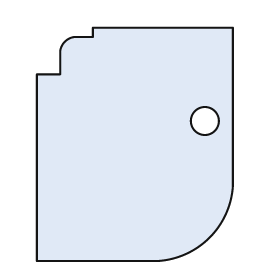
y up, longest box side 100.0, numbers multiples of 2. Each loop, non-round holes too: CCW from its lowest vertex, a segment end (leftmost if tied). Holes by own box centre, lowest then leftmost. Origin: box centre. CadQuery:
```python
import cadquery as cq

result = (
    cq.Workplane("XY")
    .moveTo(-42.0, -50.0)
    .lineTo(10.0, -50.0)
    .threePointArc((32.0, -40.0), (42.0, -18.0))
    .lineTo(42.0, 50.0)
    .lineTo(-18.0, 50.0)
    .lineTo(-18.0, 46.0)
    .lineTo(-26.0, 46.0)
    .threePointArc((-30.0, 44.0), (-32.0, 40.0))
    .lineTo(-32.0, 30.0)
    .lineTo(-42.0, 30.0)
    .close()
    .moveTo(30.0, 10.0)
    .circle(6.0)
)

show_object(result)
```